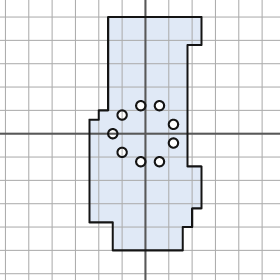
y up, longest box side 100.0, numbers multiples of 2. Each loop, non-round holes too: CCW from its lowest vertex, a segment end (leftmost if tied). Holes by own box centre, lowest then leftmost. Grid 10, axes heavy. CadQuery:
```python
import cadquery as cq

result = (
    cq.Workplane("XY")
    .moveTo(-14.0, -50.0)
    .lineTo(16.0, -50.0)
    .lineTo(16.0, -40.0)
    .lineTo(20.0, -40.0)
    .lineTo(20.0, -32.0)
    .lineTo(24.0, -32.0)
    .lineTo(24.0, -14.0)
    .lineTo(18.0, -14.0)
    .lineTo(18.0, 38.0)
    .lineTo(24.0, 38.0)
    .lineTo(24.0, 50.0)
    .lineTo(-16.0, 50.0)
    .lineTo(-16.0, 10.0)
    .lineTo(-20.0, 10.0)
    .lineTo(-20.0, 6.0)
    .lineTo(-24.0, 6.0)
    .lineTo(-24.0, -38.0)
    .lineTo(-14.0, -38.0)
    .close()
    .moveTo(-2.0, -12.0)
    .circle(2.0)
    .moveTo(6.0, -12.0)
    .circle(2.0)
    .moveTo(-10.0, -8.0)
    .circle(2.0)
    .moveTo(12.0, -4.0)
    .circle(2.0)
    .moveTo(-14.0, 0.0)
    .circle(2.0)
    .moveTo(12.0, 4.0)
    .circle(2.0)
    .moveTo(-10.0, 8.0)
    .circle(2.0)
    .moveTo(-2.0, 12.0)
    .circle(2.0)
    .moveTo(6.0, 12.0)
    .circle(2.0)
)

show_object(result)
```